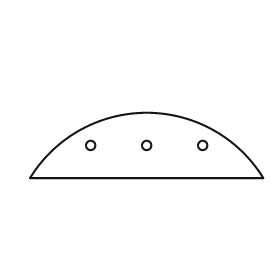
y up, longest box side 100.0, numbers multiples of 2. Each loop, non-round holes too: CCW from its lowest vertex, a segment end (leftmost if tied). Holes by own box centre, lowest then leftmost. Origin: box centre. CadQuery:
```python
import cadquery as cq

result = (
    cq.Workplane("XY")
    .moveTo(-50.0, -14.0)
    .lineTo(50.0, -14.0)
    .threePointArc((0.0, 14.0), (-50.0, -14.0))
    .close()
    .moveTo(-24.0, 0.0)
    .circle(2.0)
    .moveTo(0.0, 0.0)
    .circle(2.0)
    .moveTo(24.0, 0.0)
    .circle(2.0)
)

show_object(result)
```